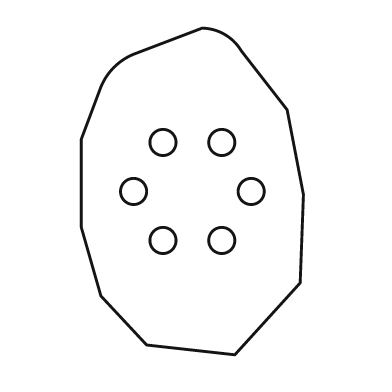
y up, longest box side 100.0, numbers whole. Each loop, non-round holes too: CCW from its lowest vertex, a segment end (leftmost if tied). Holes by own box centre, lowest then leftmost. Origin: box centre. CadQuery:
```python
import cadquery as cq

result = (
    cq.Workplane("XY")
    .moveTo(13.0, -50.0)
    .lineTo(33.0, -28.0)
    .lineTo(34.0, -1.0)
    .lineTo(29.0, 25.0)
    .lineTo(15.0, 43.0)
    .threePointArc((10.0, 48.0), (3.0, 50.0))
    .lineTo(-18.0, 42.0)
    .threePointArc((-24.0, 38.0), (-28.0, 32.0))
    .lineTo(-34.0, 16.0)
    .lineTo(-34.0, -11.0)
    .lineTo(-28.0, -32.0)
    .lineTo(-14.0, -47.0)
    .close()
    .moveTo(-9.0, -15.0)
    .circle(4.0)
    .moveTo(9.0, -15.0)
    .circle(4.0)
    .moveTo(-18.0, 0.0)
    .circle(4.0)
    .moveTo(18.0, 0.0)
    .circle(4.0)
    .moveTo(-9.0, 15.0)
    .circle(4.0)
    .moveTo(9.0, 15.0)
    .circle(4.0)
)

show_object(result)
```